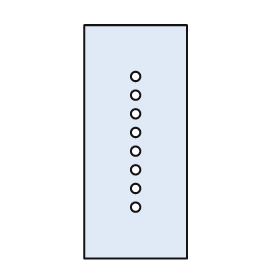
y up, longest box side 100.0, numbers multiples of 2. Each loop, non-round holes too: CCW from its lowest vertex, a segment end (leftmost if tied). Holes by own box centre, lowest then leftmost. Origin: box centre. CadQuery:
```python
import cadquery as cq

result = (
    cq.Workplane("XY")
    .moveTo(-22.0, -50.0)
    .lineTo(22.0, -50.0)
    .lineTo(22.0, 50.0)
    .lineTo(-22.0, 50.0)
    .close()
    .moveTo(0.0, -28.0)
    .circle(2.0)
    .moveTo(0.0, -20.0)
    .circle(2.0)
    .moveTo(0.0, -12.0)
    .circle(2.0)
    .moveTo(0.0, -4.0)
    .circle(2.0)
    .moveTo(0.0, 4.0)
    .circle(2.0)
    .moveTo(0.0, 12.0)
    .circle(2.0)
    .moveTo(0.0, 20.0)
    .circle(2.0)
    .moveTo(0.0, 28.0)
    .circle(2.0)
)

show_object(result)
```